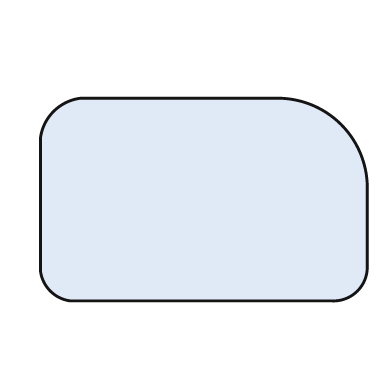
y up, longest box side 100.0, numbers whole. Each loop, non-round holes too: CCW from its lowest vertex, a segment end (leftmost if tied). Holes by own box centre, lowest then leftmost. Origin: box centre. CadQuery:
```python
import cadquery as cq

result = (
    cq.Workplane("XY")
    .moveTo(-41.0, -31.0)
    .lineTo(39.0, -31.0)
    .threePointArc((47.0, -28.0), (50.0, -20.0))
    .lineTo(50.0, 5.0)
    .threePointArc((42.0, 23.0), (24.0, 31.0))
    .lineTo(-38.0, 31.0)
    .threePointArc((-46.0, 27.0), (-50.0, 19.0))
    .lineTo(-50.0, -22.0)
    .threePointArc((-47.0, -28.0), (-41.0, -31.0))
    .close()
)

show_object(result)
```